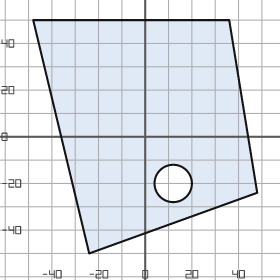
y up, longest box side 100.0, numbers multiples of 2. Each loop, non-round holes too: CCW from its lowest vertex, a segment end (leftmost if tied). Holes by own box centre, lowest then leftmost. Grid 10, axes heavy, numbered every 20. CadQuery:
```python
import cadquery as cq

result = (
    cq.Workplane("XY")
    .moveTo(-24.0, -50.0)
    .lineTo(48.0, -24.0)
    .lineTo(36.0, 50.0)
    .lineTo(-48.0, 50.0)
    .close()
    .moveTo(12.0, -20.0)
    .circle(8.0)
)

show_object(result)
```